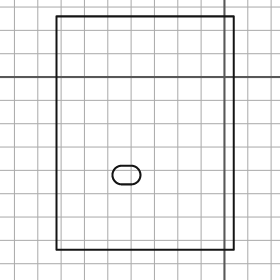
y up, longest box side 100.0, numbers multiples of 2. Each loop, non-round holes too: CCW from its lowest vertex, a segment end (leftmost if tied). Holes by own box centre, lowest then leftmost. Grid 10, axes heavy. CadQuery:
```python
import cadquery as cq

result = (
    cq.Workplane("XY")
    .moveTo(-72.0, -74.0)
    .lineTo(4.0, -74.0)
    .lineTo(4.0, 26.0)
    .lineTo(-72.0, 26.0)
    .close()
    .moveTo(-44.0, -46.0)
    .lineTo(-40.0, -46.0)
    .threePointArc((-36.0, -42.0), (-40.0, -38.0))
    .lineTo(-44.0, -38.0)
    .threePointArc((-48.0, -42.0), (-44.0, -46.0))
    .close()
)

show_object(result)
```